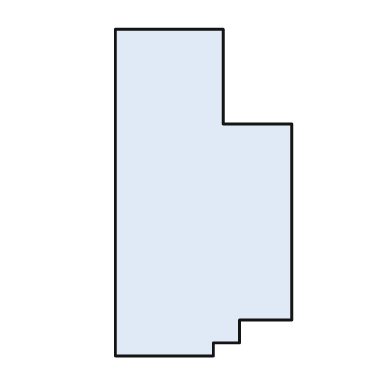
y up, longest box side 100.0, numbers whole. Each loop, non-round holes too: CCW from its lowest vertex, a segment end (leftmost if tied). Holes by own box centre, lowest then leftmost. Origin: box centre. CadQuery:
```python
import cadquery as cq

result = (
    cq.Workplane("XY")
    .moveTo(-27.0, -50.0)
    .lineTo(3.0, -50.0)
    .lineTo(3.0, -46.0)
    .lineTo(11.0, -46.0)
    .lineTo(11.0, -39.0)
    .lineTo(27.0, -39.0)
    .lineTo(27.0, 21.0)
    .lineTo(6.0, 21.0)
    .lineTo(6.0, 50.0)
    .lineTo(-27.0, 50.0)
    .close()
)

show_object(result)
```